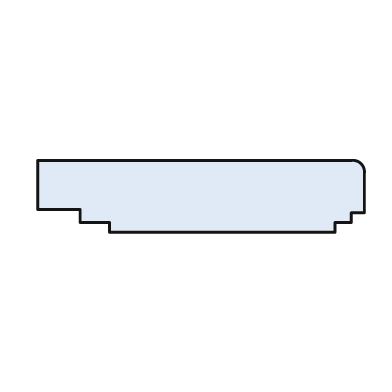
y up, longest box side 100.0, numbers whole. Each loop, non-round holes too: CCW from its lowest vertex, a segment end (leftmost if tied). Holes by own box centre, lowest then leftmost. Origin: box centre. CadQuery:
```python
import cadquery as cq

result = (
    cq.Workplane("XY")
    .moveTo(-28.0, -11.0)
    .lineTo(41.0, -11.0)
    .lineTo(41.0, -8.0)
    .lineTo(46.0, -8.0)
    .lineTo(46.0, -5.0)
    .lineTo(50.0, -5.0)
    .lineTo(50.0, 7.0)
    .threePointArc((49.0, 10.0), (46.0, 11.0))
    .lineTo(-50.0, 11.0)
    .lineTo(-50.0, -4.0)
    .lineTo(-37.0, -4.0)
    .lineTo(-37.0, -8.0)
    .lineTo(-28.0, -8.0)
    .close()
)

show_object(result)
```